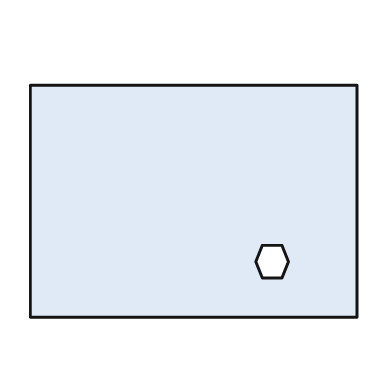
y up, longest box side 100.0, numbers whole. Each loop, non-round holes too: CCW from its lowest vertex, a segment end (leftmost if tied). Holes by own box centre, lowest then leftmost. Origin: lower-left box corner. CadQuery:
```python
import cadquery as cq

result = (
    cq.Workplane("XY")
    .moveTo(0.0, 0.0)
    .lineTo(100.0, 0.0)
    .lineTo(100.0, 71.0)
    .lineTo(0.0, 71.0)
    .close()
    .moveTo(71.0, 12.0)
    .lineTo(77.0, 12.0)
    .lineTo(79.0, 17.0)
    .lineTo(77.0, 22.0)
    .lineTo(71.0, 22.0)
    .lineTo(69.0, 17.0)
    .close()
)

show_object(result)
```